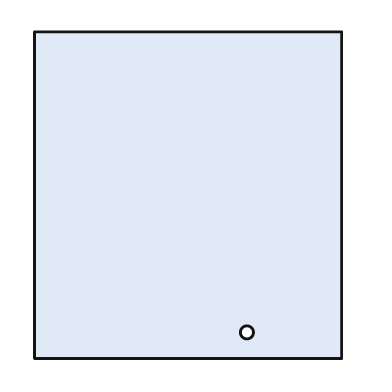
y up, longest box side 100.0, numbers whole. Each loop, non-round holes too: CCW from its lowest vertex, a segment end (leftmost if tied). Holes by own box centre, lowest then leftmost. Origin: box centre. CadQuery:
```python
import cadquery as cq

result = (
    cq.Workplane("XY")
    .moveTo(-47.0, -50.0)
    .lineTo(47.0, -50.0)
    .lineTo(47.0, 50.0)
    .lineTo(-47.0, 50.0)
    .close()
    .moveTo(18.0, -42.0)
    .circle(2.0)
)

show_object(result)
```